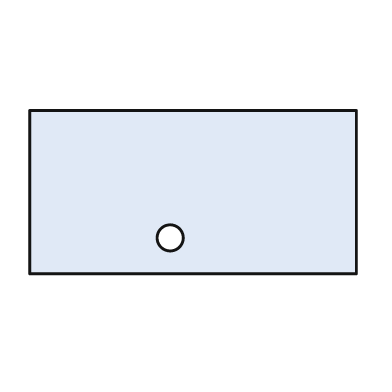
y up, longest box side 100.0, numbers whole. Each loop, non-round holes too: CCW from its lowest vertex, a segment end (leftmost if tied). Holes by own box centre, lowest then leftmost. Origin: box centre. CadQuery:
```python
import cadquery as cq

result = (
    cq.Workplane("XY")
    .moveTo(-50.0, -25.0)
    .lineTo(50.0, -25.0)
    .lineTo(50.0, 25.0)
    .lineTo(-50.0, 25.0)
    .close()
    .moveTo(-7.0, -14.0)
    .circle(4.0)
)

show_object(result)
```